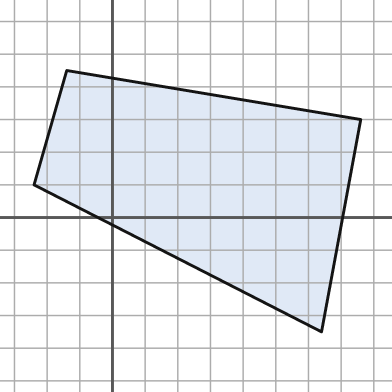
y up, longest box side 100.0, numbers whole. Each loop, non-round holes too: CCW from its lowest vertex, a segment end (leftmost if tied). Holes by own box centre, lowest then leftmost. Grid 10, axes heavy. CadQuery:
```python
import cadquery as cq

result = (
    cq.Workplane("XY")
    .moveTo(64.0, -35.0)
    .lineTo(76.0, 30.0)
    .lineTo(-14.0, 45.0)
    .lineTo(-24.0, 10.0)
    .close()
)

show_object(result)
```